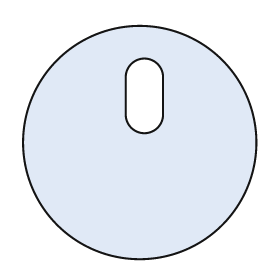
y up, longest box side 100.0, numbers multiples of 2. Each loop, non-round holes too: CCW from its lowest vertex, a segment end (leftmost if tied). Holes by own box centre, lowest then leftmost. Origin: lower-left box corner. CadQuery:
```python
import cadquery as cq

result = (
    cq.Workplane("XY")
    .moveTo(50.0, 50.0)
    .circle(50.0)
    .moveTo(44.0, 62.0)
    .threePointArc((52.0, 54.0), (60.0, 62.0))
    .lineTo(60.0, 78.0)
    .threePointArc((52.0, 86.0), (44.0, 78.0))
    .close()
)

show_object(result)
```